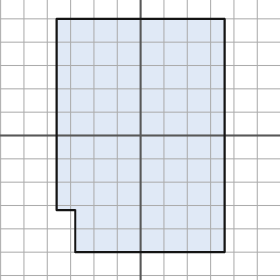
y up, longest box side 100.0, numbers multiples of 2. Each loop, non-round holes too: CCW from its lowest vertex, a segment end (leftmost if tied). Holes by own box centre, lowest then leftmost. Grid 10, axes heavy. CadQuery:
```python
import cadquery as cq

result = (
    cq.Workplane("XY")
    .moveTo(-28.0, -50.0)
    .lineTo(36.0, -50.0)
    .lineTo(36.0, 50.0)
    .lineTo(-36.0, 50.0)
    .lineTo(-36.0, -32.0)
    .lineTo(-28.0, -32.0)
    .close()
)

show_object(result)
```